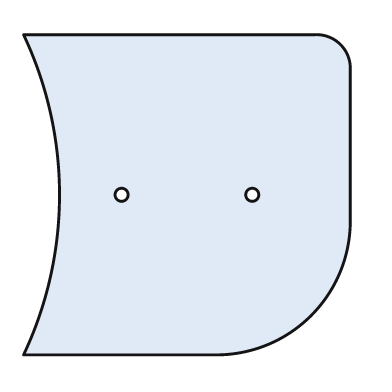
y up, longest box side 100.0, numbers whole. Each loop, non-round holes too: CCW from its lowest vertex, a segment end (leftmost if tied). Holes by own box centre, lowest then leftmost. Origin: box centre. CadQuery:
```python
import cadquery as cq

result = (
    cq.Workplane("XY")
    .moveTo(-50.0, -49.0)
    .lineTo(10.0, -49.0)
    .threePointArc((38.0, -37.0), (50.0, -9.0))
    .lineTo(50.0, 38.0)
    .threePointArc((47.0, 46.0), (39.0, 49.0))
    .lineTo(-50.0, 49.0)
    .threePointArc((-39.0, 0.0), (-50.0, -49.0))
    .close()
    .moveTo(-20.0, 0.0)
    .circle(2.0)
    .moveTo(20.0, 0.0)
    .circle(2.0)
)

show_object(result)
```